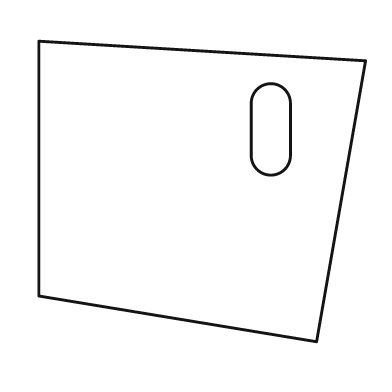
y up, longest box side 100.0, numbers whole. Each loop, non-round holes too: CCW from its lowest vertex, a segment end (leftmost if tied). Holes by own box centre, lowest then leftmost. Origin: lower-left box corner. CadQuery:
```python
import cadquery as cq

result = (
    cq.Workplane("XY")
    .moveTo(85.0, 0.0)
    .lineTo(100.0, 86.0)
    .lineTo(0.0, 92.0)
    .lineTo(0.0, 14.0)
    .close()
    .moveTo(65.0, 57.0)
    .threePointArc((71.0, 51.0), (77.0, 57.0))
    .lineTo(77.0, 73.0)
    .threePointArc((71.0, 79.0), (65.0, 73.0))
    .close()
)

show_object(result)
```